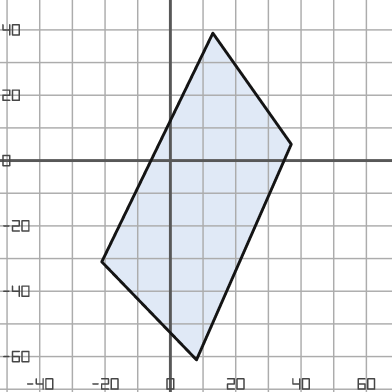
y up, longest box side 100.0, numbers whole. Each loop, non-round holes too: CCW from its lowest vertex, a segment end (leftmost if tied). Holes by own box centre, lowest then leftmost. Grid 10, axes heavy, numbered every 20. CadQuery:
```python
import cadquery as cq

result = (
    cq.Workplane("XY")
    .moveTo(8.0, -61.0)
    .lineTo(37.0, 5.0)
    .lineTo(13.0, 39.0)
    .lineTo(-21.0, -31.0)
    .close()
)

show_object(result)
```